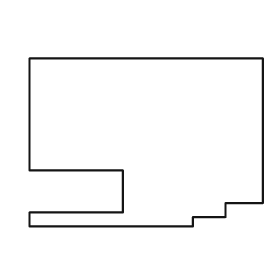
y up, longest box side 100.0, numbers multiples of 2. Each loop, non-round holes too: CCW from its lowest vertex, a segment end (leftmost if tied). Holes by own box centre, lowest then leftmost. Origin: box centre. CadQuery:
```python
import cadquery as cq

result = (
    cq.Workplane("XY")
    .moveTo(-50.0, -36.0)
    .lineTo(20.0, -36.0)
    .lineTo(20.0, -32.0)
    .lineTo(34.0, -32.0)
    .lineTo(34.0, -26.0)
    .lineTo(50.0, -26.0)
    .lineTo(50.0, 36.0)
    .lineTo(-50.0, 36.0)
    .lineTo(-50.0, -12.0)
    .lineTo(-10.0, -12.0)
    .lineTo(-10.0, -30.0)
    .lineTo(-50.0, -30.0)
    .close()
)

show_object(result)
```